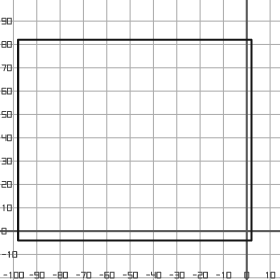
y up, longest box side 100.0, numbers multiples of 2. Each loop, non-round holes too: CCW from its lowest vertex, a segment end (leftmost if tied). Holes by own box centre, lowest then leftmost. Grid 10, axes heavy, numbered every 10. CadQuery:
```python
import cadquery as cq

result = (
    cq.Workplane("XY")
    .moveTo(-98.0, -4.0)
    .lineTo(2.0, -4.0)
    .lineTo(2.0, 82.0)
    .lineTo(-98.0, 82.0)
    .close()
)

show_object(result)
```